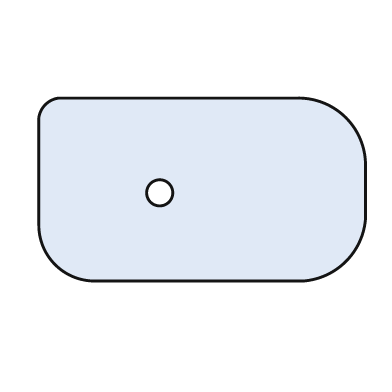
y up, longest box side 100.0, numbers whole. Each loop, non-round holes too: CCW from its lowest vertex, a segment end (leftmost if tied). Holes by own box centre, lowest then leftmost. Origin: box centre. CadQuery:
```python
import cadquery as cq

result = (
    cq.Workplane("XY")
    .moveTo(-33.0, -28.0)
    .lineTo(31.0, -28.0)
    .threePointArc((44.0, -22.0), (50.0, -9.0))
    .lineTo(50.0, 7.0)
    .threePointArc((44.0, 22.0), (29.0, 28.0))
    .lineTo(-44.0, 28.0)
    .threePointArc((-48.0, 26.0), (-50.0, 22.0))
    .lineTo(-50.0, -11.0)
    .threePointArc((-45.0, -23.0), (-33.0, -28.0))
    .close()
    .moveTo(-13.0, -1.0)
    .circle(4.0)
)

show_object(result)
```